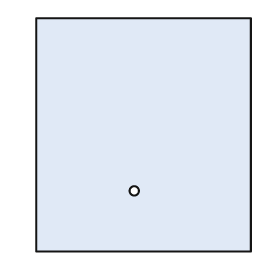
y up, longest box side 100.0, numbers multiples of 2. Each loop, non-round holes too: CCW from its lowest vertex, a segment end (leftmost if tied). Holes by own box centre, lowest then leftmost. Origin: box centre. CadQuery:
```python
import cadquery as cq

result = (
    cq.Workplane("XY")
    .moveTo(-46.0, -50.0)
    .lineTo(46.0, -50.0)
    .lineTo(46.0, 50.0)
    .lineTo(-46.0, 50.0)
    .close()
    .moveTo(-4.0, -24.0)
    .circle(2.0)
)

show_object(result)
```